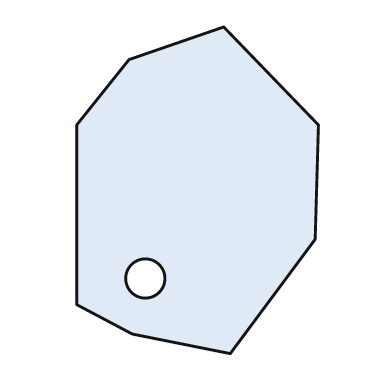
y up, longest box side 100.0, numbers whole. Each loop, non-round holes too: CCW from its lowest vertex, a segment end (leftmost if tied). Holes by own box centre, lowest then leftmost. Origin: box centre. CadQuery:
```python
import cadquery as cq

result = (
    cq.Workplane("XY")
    .moveTo(10.0, -50.0)
    .lineTo(36.0, -15.0)
    .lineTo(37.0, 20.0)
    .lineTo(8.0, 50.0)
    .lineTo(-21.0, 40.0)
    .lineTo(-37.0, 20.0)
    .lineTo(-37.0, -35.0)
    .lineTo(-20.0, -44.0)
    .close()
    .moveTo(-16.0, -27.0)
    .circle(6.0)
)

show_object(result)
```